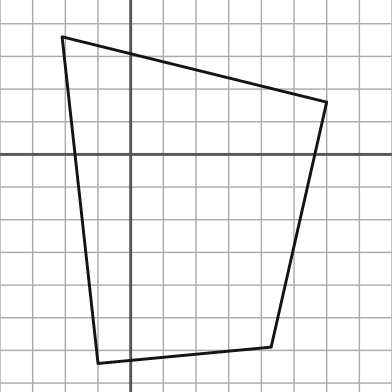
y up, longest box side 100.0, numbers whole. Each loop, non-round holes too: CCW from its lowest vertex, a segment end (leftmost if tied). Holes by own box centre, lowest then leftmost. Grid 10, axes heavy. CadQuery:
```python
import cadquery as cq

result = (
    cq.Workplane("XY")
    .moveTo(-10.0, -64.0)
    .lineTo(43.0, -59.0)
    .lineTo(60.0, 16.0)
    .lineTo(-21.0, 36.0)
    .close()
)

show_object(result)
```